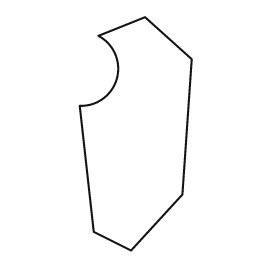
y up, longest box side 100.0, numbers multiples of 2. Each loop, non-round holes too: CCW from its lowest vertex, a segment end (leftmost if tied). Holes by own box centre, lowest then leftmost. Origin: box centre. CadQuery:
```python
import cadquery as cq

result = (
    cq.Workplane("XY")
    .moveTo(-2.0, -50.0)
    .lineTo(20.0, -26.0)
    .lineTo(24.0, 32.0)
    .lineTo(4.0, 50.0)
    .lineTo(-16.0, 42.0)
    .threePointArc((-8.0, 24.0), (-24.0, 12.0))
    .lineTo(-18.0, -42.0)
    .close()
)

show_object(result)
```